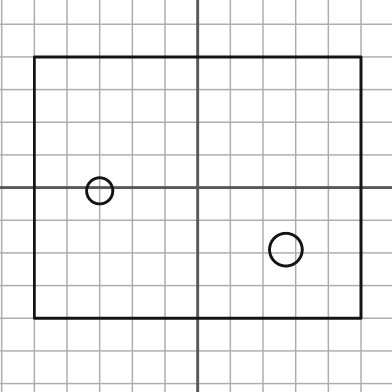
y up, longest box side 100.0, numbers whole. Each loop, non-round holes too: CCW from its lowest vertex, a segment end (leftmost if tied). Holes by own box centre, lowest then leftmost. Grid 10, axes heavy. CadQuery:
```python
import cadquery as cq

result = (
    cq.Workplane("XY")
    .moveTo(-50.0, -40.0)
    .lineTo(50.0, -40.0)
    .lineTo(50.0, 40.0)
    .lineTo(-50.0, 40.0)
    .close()
    .moveTo(27.0, -19.0)
    .circle(5.0)
    .moveTo(-30.0, -1.0)
    .circle(4.0)
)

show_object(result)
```